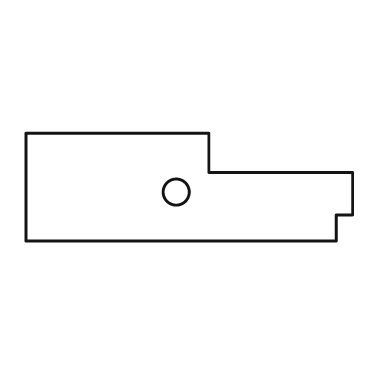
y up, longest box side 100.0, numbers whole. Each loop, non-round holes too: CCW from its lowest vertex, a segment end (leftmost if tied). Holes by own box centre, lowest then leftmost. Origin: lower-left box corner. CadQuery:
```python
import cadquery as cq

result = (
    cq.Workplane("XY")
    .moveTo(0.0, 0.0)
    .lineTo(95.0, 0.0)
    .lineTo(95.0, 8.0)
    .lineTo(100.0, 8.0)
    .lineTo(100.0, 21.0)
    .lineTo(56.0, 21.0)
    .lineTo(56.0, 33.0)
    .lineTo(0.0, 33.0)
    .close()
    .moveTo(46.0, 15.0)
    .circle(4.0)
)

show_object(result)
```